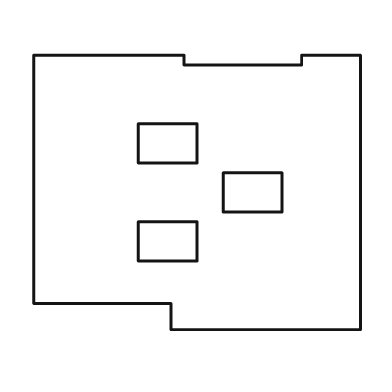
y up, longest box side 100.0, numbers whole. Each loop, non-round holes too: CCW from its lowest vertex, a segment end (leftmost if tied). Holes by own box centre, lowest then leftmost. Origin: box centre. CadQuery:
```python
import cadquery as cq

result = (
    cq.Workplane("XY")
    .moveTo(-8.0, -42.0)
    .lineTo(50.0, -42.0)
    .lineTo(50.0, 42.0)
    .lineTo(32.0, 42.0)
    .lineTo(32.0, 39.0)
    .lineTo(-4.0, 39.0)
    .lineTo(-4.0, 42.0)
    .lineTo(-50.0, 42.0)
    .lineTo(-50.0, -34.0)
    .lineTo(-8.0, -34.0)
    .close()
    .moveTo(-18.0, -21.0)
    .lineTo(0.0, -21.0)
    .lineTo(0.0, -9.0)
    .lineTo(-18.0, -9.0)
    .close()
    .moveTo(8.0, -6.0)
    .lineTo(26.0, -6.0)
    .lineTo(26.0, 6.0)
    .lineTo(8.0, 6.0)
    .close()
    .moveTo(-18.0, 9.0)
    .lineTo(0.0, 9.0)
    .lineTo(0.0, 21.0)
    .lineTo(-18.0, 21.0)
    .close()
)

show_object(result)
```